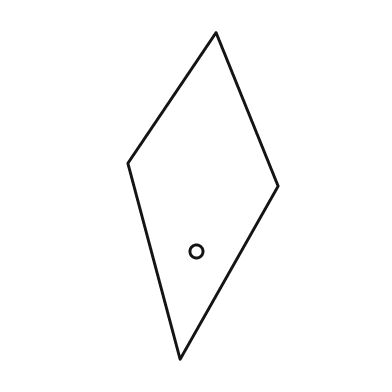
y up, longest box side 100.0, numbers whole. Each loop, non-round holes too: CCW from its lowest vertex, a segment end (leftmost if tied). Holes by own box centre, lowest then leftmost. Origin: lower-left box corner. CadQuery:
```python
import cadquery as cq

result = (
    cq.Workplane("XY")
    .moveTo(16.0, 0.0)
    .lineTo(46.0, 53.0)
    .lineTo(27.0, 100.0)
    .lineTo(0.0, 60.0)
    .close()
    .moveTo(21.0, 33.0)
    .circle(2.0)
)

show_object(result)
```